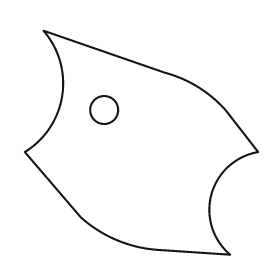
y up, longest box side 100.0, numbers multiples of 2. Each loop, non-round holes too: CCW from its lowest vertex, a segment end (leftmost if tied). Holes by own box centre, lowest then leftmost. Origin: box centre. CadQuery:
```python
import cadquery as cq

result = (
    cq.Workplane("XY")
    .moveTo(38.0, -48.0)
    .threePointArc((30.0, -22.0), (50.0, -4.0))
    .lineTo(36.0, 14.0)
    .threePointArc((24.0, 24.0), (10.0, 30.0))
    .lineTo(-42.0, 48.0)
    .threePointArc((-34.0, 20.0), (-50.0, -4.0))
    .lineTo(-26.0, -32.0)
    .threePointArc((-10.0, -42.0), (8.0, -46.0))
    .close()
    .moveTo(-16.0, 14.0)
    .circle(6.0)
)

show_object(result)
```